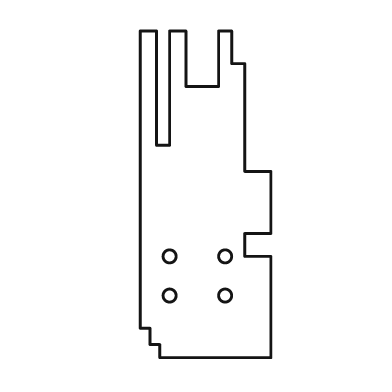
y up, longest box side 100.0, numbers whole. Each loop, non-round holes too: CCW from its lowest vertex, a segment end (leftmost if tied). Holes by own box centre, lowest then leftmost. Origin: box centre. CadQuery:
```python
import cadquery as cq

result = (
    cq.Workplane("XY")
    .moveTo(-14.0, -50.0)
    .lineTo(20.0, -50.0)
    .lineTo(20.0, -19.0)
    .lineTo(12.0, -19.0)
    .lineTo(12.0, -12.0)
    .lineTo(20.0, -12.0)
    .lineTo(20.0, 7.0)
    .lineTo(12.0, 7.0)
    .lineTo(12.0, 40.0)
    .lineTo(8.0, 40.0)
    .lineTo(8.0, 50.0)
    .lineTo(4.0, 50.0)
    .lineTo(4.0, 33.0)
    .lineTo(-6.0, 33.0)
    .lineTo(-6.0, 50.0)
    .lineTo(-11.0, 50.0)
    .lineTo(-11.0, 15.0)
    .lineTo(-15.0, 15.0)
    .lineTo(-15.0, 50.0)
    .lineTo(-20.0, 50.0)
    .lineTo(-20.0, -41.0)
    .lineTo(-17.0, -41.0)
    .lineTo(-17.0, -46.0)
    .lineTo(-14.0, -46.0)
    .close()
    .moveTo(-11.0, -31.0)
    .circle(2.0)
    .moveTo(6.0, -31.0)
    .circle(2.0)
    .moveTo(-11.0, -19.0)
    .circle(2.0)
    .moveTo(6.0, -19.0)
    .circle(2.0)
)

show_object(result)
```